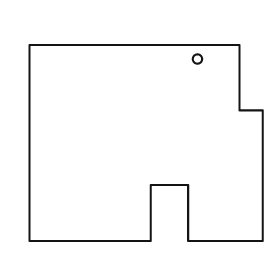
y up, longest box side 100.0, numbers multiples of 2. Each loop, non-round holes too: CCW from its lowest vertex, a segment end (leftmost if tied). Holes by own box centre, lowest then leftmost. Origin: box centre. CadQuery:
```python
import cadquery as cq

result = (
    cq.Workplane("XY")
    .moveTo(-50.0, -42.0)
    .lineTo(2.0, -42.0)
    .lineTo(2.0, -18.0)
    .lineTo(18.0, -18.0)
    .lineTo(18.0, -42.0)
    .lineTo(50.0, -42.0)
    .lineTo(50.0, 14.0)
    .lineTo(40.0, 14.0)
    .lineTo(40.0, 42.0)
    .lineTo(-50.0, 42.0)
    .close()
    .moveTo(22.0, 36.0)
    .circle(2.0)
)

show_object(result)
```